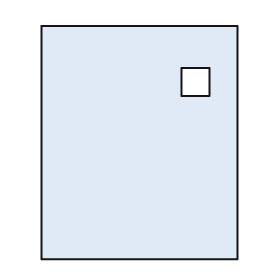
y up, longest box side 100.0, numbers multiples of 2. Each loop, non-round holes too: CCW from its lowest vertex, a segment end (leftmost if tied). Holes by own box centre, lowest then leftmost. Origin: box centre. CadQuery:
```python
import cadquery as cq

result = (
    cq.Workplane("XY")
    .moveTo(-42.0, -50.0)
    .lineTo(42.0, -50.0)
    .lineTo(42.0, 50.0)
    .lineTo(-42.0, 50.0)
    .close()
    .moveTo(18.0, 20.0)
    .lineTo(30.0, 20.0)
    .lineTo(30.0, 32.0)
    .lineTo(18.0, 32.0)
    .close()
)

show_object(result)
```